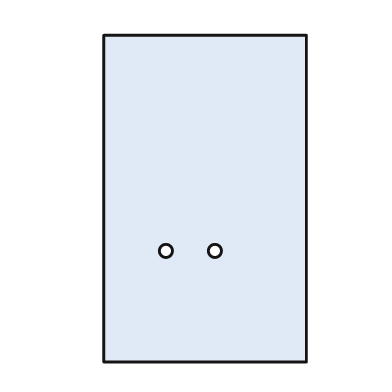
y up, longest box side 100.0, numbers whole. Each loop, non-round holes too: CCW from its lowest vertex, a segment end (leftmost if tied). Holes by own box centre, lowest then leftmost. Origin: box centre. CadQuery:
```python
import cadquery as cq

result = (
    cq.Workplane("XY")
    .moveTo(-31.0, -50.0)
    .lineTo(31.0, -50.0)
    .lineTo(31.0, 50.0)
    .lineTo(-31.0, 50.0)
    .close()
    .moveTo(-12.0, -16.0)
    .circle(2.0)
    .moveTo(3.0, -16.0)
    .circle(2.0)
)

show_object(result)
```